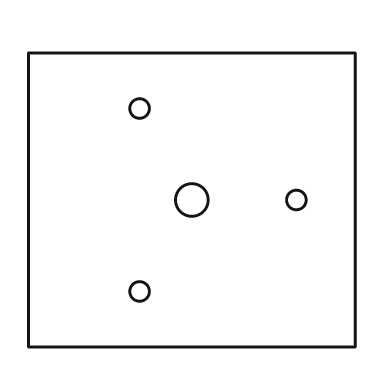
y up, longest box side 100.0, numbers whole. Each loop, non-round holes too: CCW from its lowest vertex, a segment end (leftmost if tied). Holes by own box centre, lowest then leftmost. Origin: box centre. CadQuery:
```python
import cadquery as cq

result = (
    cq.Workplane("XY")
    .moveTo(-50.0, -45.0)
    .lineTo(50.0, -45.0)
    .lineTo(50.0, 45.0)
    .lineTo(-50.0, 45.0)
    .close()
    .moveTo(-16.0, -28.0)
    .circle(3.0)
    .moveTo(0.0, 0.0)
    .circle(5.0)
    .moveTo(32.0, 0.0)
    .circle(3.0)
    .moveTo(-16.0, 28.0)
    .circle(3.0)
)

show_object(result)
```